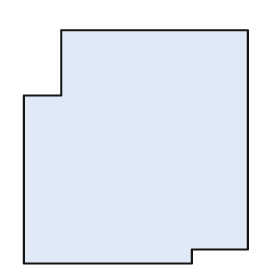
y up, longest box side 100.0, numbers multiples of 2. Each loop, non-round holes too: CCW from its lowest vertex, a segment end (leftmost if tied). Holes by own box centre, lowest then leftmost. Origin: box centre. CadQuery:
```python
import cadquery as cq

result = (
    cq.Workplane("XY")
    .moveTo(-48.0, -50.0)
    .lineTo(24.0, -50.0)
    .lineTo(24.0, -44.0)
    .lineTo(48.0, -44.0)
    .lineTo(48.0, 50.0)
    .lineTo(-32.0, 50.0)
    .lineTo(-32.0, 22.0)
    .lineTo(-48.0, 22.0)
    .close()
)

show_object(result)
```